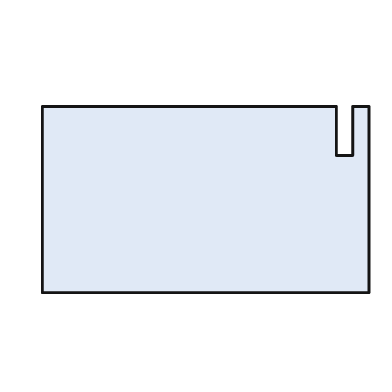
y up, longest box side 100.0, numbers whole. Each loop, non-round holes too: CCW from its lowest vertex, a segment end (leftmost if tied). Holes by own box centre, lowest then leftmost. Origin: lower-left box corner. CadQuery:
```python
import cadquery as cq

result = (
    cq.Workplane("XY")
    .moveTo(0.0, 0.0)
    .lineTo(100.0, 0.0)
    .lineTo(100.0, 57.0)
    .lineTo(95.0, 57.0)
    .lineTo(95.0, 42.0)
    .lineTo(90.0, 42.0)
    .lineTo(90.0, 57.0)
    .lineTo(0.0, 57.0)
    .close()
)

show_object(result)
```